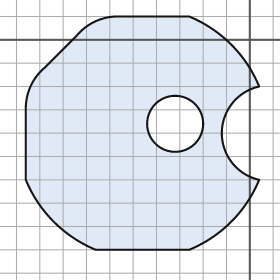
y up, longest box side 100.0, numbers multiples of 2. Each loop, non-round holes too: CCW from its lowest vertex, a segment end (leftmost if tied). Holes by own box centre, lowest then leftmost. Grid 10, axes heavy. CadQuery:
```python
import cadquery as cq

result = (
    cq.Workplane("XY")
    .moveTo(-66.0, -90.0)
    .lineTo(-26.0, -90.0)
    .threePointArc((-8.0, -78.0), (4.0, -60.0))
    .threePointArc((-12.0, -40.0), (4.0, -20.0))
    .threePointArc((-8.0, -2.0), (-26.0, 10.0))
    .lineTo(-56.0, 10.0)
    .threePointArc((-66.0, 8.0), (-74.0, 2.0))
    .lineTo(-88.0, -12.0)
    .threePointArc((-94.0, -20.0), (-96.0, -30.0))
    .lineTo(-96.0, -60.0)
    .threePointArc((-84.0, -78.0), (-66.0, -90.0))
    .close()
    .moveTo(-32.0, -36.0)
    .circle(12.0)
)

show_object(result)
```